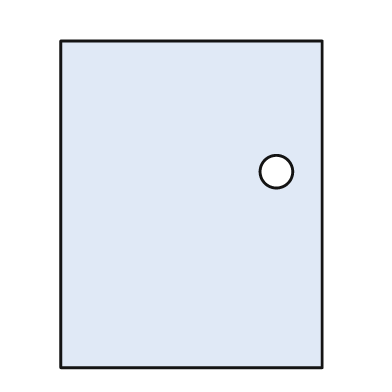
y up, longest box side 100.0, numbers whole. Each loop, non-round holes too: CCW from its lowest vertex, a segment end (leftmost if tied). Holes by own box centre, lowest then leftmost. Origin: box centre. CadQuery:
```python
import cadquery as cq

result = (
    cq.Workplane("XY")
    .moveTo(-40.0, -50.0)
    .lineTo(40.0, -50.0)
    .lineTo(40.0, 50.0)
    .lineTo(-40.0, 50.0)
    .close()
    .moveTo(26.0, 10.0)
    .circle(5.0)
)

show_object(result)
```